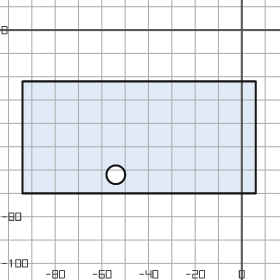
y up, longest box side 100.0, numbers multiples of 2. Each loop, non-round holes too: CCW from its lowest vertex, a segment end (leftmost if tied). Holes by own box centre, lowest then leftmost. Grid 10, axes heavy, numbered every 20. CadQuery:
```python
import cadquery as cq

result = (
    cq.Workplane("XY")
    .moveTo(-94.0, -70.0)
    .lineTo(6.0, -70.0)
    .lineTo(6.0, -22.0)
    .lineTo(-94.0, -22.0)
    .close()
    .moveTo(-54.0, -62.0)
    .circle(4.0)
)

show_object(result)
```